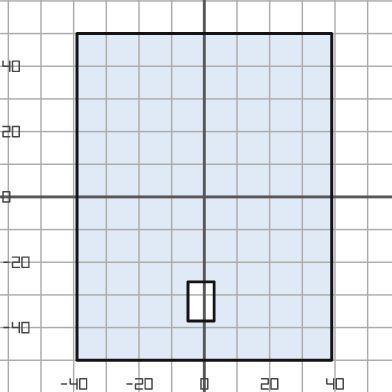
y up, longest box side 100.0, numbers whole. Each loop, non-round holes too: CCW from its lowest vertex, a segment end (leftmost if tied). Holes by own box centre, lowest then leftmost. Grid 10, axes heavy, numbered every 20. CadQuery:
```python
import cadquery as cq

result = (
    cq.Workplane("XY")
    .moveTo(-39.0, -50.0)
    .lineTo(39.0, -50.0)
    .lineTo(39.0, 50.0)
    .lineTo(-39.0, 50.0)
    .close()
    .moveTo(-5.0, -38.0)
    .lineTo(3.0, -38.0)
    .lineTo(3.0, -26.0)
    .lineTo(-5.0, -26.0)
    .close()
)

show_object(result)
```